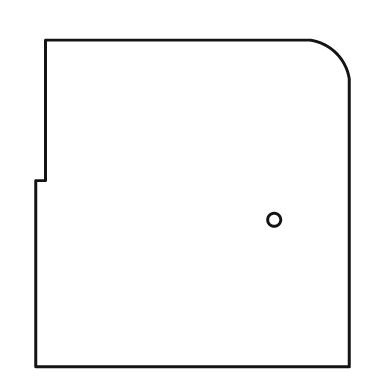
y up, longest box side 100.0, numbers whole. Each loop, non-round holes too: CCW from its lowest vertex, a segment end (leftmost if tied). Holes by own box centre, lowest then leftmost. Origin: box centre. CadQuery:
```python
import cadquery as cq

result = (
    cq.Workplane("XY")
    .moveTo(-48.0, -50.0)
    .lineTo(48.0, -50.0)
    .lineTo(48.0, 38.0)
    .threePointArc((44.0, 46.0), (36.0, 50.0))
    .lineTo(-45.0, 50.0)
    .lineTo(-45.0, 7.0)
    .lineTo(-48.0, 7.0)
    .close()
    .moveTo(25.0, -5.0)
    .circle(2.0)
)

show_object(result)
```